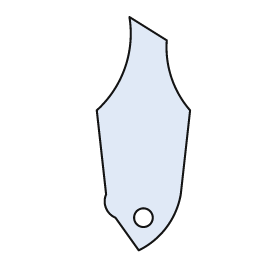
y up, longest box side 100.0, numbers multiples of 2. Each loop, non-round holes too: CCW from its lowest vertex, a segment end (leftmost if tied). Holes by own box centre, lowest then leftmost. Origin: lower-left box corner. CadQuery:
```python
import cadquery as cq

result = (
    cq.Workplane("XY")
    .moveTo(18.0, 0.0)
    .threePointArc((30.0, 10.0), (36.0, 24.0))
    .lineTo(40.0, 60.0)
    .threePointArc((32.0, 74.0), (30.0, 90.0))
    .lineTo(14.0, 100.0)
    .threePointArc((12.0, 78.0), (0.0, 60.0))
    .lineTo(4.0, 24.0)
    .threePointArc((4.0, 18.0), (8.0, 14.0))
    .close()
    .moveTo(20.0, 14.0)
    .circle(4.0)
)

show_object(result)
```